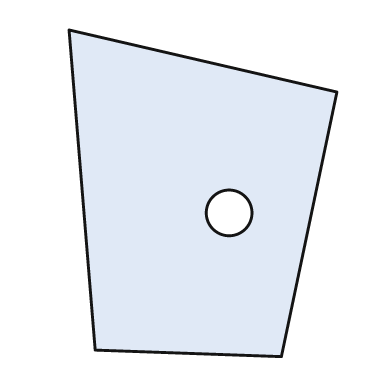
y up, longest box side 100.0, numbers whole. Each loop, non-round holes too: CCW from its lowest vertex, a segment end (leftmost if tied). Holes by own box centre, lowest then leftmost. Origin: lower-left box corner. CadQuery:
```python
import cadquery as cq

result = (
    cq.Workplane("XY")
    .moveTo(65.0, 0.0)
    .lineTo(82.0, 81.0)
    .lineTo(0.0, 100.0)
    .lineTo(8.0, 2.0)
    .close()
    .moveTo(49.0, 44.0)
    .circle(7.0)
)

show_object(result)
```